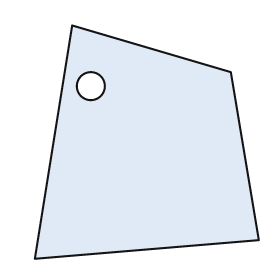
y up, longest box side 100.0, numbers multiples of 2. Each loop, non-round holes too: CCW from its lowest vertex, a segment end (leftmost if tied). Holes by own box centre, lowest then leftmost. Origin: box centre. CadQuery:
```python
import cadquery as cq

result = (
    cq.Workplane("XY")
    .moveTo(-48.0, -50.0)
    .lineTo(48.0, -42.0)
    .lineTo(36.0, 30.0)
    .lineTo(-32.0, 50.0)
    .close()
    .moveTo(-24.0, 24.0)
    .circle(6.0)
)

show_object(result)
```